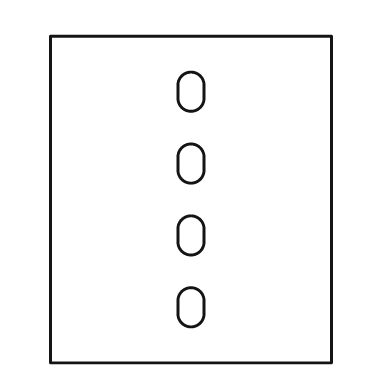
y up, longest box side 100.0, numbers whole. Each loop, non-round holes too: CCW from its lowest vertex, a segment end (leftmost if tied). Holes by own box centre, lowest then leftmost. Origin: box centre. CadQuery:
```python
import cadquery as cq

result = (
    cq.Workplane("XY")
    .moveTo(-43.0, -50.0)
    .lineTo(43.0, -50.0)
    .lineTo(43.0, 50.0)
    .lineTo(-43.0, 50.0)
    .close()
    .moveTo(-4.0, -35.0)
    .threePointArc((0.0, -39.0), (4.0, -35.0))
    .lineTo(4.0, -31.0)
    .threePointArc((0.0, -27.0), (-4.0, -31.0))
    .close()
    .moveTo(-4.0, -13.0)
    .threePointArc((0.0, -17.0), (4.0, -13.0))
    .lineTo(4.0, -9.0)
    .threePointArc((0.0, -5.0), (-4.0, -9.0))
    .close()
    .moveTo(-4.0, 9.0)
    .threePointArc((0.0, 5.0), (4.0, 9.0))
    .lineTo(4.0, 13.0)
    .threePointArc((0.0, 17.0), (-4.0, 13.0))
    .close()
    .moveTo(-4.0, 31.0)
    .threePointArc((0.0, 27.0), (4.0, 31.0))
    .lineTo(4.0, 35.0)
    .threePointArc((0.0, 39.0), (-4.0, 35.0))
    .close()
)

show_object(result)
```